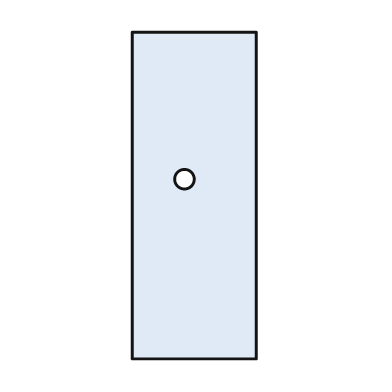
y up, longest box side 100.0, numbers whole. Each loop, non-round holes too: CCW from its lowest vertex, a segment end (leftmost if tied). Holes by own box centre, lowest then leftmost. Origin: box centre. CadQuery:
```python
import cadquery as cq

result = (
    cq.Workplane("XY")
    .moveTo(-19.0, -50.0)
    .lineTo(19.0, -50.0)
    .lineTo(19.0, 50.0)
    .lineTo(-19.0, 50.0)
    .close()
    .moveTo(-3.0, 5.0)
    .circle(3.0)
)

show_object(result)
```